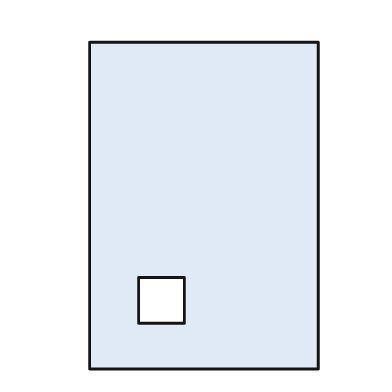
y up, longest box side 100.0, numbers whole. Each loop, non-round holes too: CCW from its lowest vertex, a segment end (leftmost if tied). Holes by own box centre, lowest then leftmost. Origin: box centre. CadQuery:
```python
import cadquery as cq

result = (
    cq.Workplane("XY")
    .moveTo(-35.0, -50.0)
    .lineTo(35.0, -50.0)
    .lineTo(35.0, 50.0)
    .lineTo(-35.0, 50.0)
    .close()
    .moveTo(-20.0, -36.0)
    .lineTo(-6.0, -36.0)
    .lineTo(-6.0, -22.0)
    .lineTo(-20.0, -22.0)
    .close()
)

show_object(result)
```